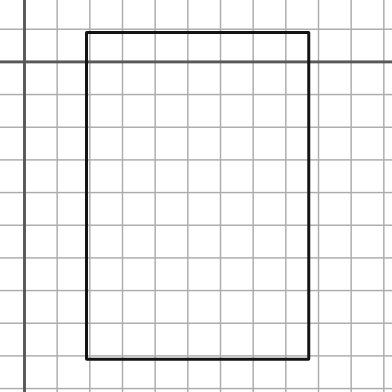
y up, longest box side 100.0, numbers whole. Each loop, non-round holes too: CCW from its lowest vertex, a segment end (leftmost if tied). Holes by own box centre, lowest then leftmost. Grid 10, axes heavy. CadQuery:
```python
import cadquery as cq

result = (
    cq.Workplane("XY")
    .moveTo(19.0, -91.0)
    .lineTo(87.0, -91.0)
    .lineTo(87.0, 9.0)
    .lineTo(19.0, 9.0)
    .close()
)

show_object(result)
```